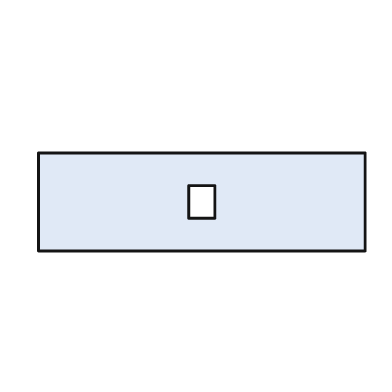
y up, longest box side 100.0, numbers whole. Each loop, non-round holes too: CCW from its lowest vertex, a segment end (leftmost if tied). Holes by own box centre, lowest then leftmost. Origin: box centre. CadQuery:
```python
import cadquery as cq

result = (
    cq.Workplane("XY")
    .moveTo(-50.0, -15.0)
    .lineTo(50.0, -15.0)
    .lineTo(50.0, 15.0)
    .lineTo(-50.0, 15.0)
    .close()
    .moveTo(-4.0, -5.0)
    .lineTo(4.0, -5.0)
    .lineTo(4.0, 5.0)
    .lineTo(-4.0, 5.0)
    .close()
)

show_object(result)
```